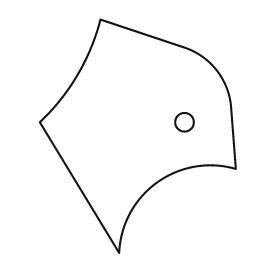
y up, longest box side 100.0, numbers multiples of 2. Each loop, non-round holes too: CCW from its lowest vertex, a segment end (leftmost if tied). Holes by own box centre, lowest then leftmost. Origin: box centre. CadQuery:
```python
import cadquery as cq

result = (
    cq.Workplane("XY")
    .moveTo(-8.0, -50.0)
    .threePointArc((8.0, -20.0), (42.0, -14.0))
    .lineTo(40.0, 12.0)
    .threePointArc((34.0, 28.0), (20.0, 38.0))
    .lineTo(-16.0, 50.0)
    .threePointArc((-26.0, 26.0), (-42.0, 6.0))
    .close()
    .moveTo(20.0, 6.0)
    .circle(4.0)
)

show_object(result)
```